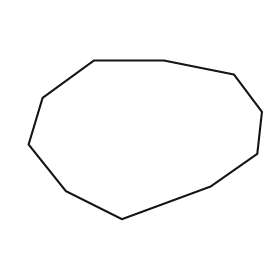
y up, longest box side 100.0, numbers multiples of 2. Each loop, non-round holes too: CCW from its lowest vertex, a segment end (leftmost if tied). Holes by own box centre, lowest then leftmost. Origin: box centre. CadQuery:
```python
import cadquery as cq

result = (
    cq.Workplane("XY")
    .moveTo(-10.0, -34.0)
    .lineTo(28.0, -20.0)
    .lineTo(48.0, -6.0)
    .lineTo(50.0, 12.0)
    .lineTo(38.0, 28.0)
    .lineTo(8.0, 34.0)
    .lineTo(-22.0, 34.0)
    .lineTo(-44.0, 18.0)
    .lineTo(-50.0, -2.0)
    .lineTo(-34.0, -22.0)
    .close()
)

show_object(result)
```